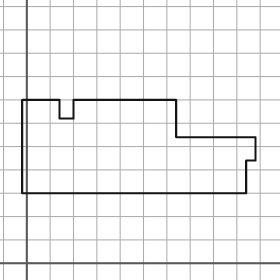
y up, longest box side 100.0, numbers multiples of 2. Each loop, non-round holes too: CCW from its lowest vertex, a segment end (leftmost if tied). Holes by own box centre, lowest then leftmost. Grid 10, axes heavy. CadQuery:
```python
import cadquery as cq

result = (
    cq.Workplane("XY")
    .moveTo(-2.0, 30.0)
    .lineTo(94.0, 30.0)
    .lineTo(94.0, 44.0)
    .lineTo(98.0, 44.0)
    .lineTo(98.0, 54.0)
    .lineTo(64.0, 54.0)
    .lineTo(64.0, 70.0)
    .lineTo(20.0, 70.0)
    .lineTo(20.0, 62.0)
    .lineTo(14.0, 62.0)
    .lineTo(14.0, 70.0)
    .lineTo(-2.0, 70.0)
    .close()
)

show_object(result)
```